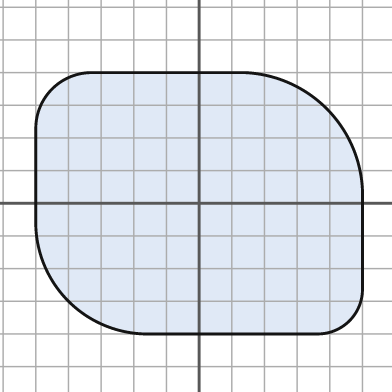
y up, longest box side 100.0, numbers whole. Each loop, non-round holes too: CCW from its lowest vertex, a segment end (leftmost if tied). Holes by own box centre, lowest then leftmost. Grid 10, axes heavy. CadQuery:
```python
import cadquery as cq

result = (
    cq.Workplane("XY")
    .moveTo(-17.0, -40.0)
    .lineTo(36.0, -40.0)
    .threePointArc((46.0, -36.0), (50.0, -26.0))
    .lineTo(50.0, 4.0)
    .threePointArc((39.0, 29.0), (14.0, 40.0))
    .lineTo(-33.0, 40.0)
    .threePointArc((-45.0, 35.0), (-50.0, 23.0))
    .lineTo(-50.0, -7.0)
    .threePointArc((-40.0, -30.0), (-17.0, -40.0))
    .close()
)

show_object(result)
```